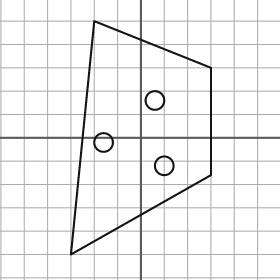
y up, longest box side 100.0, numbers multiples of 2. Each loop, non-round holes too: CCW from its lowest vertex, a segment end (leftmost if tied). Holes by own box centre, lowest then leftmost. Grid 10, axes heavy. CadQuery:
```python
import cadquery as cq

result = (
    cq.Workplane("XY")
    .moveTo(-30.0, -50.0)
    .lineTo(30.0, -16.0)
    .lineTo(30.0, 30.0)
    .lineTo(-20.0, 50.0)
    .close()
    .moveTo(10.0, -12.0)
    .circle(4.0)
    .moveTo(-16.0, -2.0)
    .circle(4.0)
    .moveTo(6.0, 16.0)
    .circle(4.0)
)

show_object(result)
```